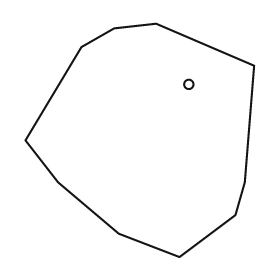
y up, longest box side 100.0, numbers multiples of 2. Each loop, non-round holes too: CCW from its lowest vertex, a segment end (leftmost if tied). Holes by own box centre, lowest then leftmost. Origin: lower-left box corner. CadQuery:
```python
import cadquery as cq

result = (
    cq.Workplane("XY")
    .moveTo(66.0, 0.0)
    .lineTo(90.0, 18.0)
    .lineTo(94.0, 32.0)
    .lineTo(98.0, 82.0)
    .lineTo(56.0, 100.0)
    .lineTo(38.0, 98.0)
    .lineTo(24.0, 90.0)
    .lineTo(0.0, 50.0)
    .lineTo(14.0, 32.0)
    .lineTo(40.0, 10.0)
    .close()
    .moveTo(70.0, 74.0)
    .circle(2.0)
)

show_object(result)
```